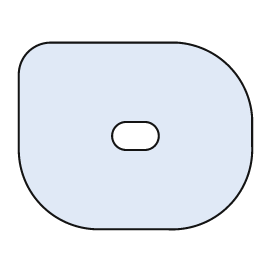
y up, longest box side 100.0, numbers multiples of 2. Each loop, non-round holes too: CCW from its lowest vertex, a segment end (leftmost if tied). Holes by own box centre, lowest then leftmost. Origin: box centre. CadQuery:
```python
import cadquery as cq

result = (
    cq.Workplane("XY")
    .moveTo(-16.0, -40.0)
    .lineTo(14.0, -40.0)
    .threePointArc((40.0, -30.0), (50.0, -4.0))
    .lineTo(50.0, 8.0)
    .threePointArc((40.0, 30.0), (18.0, 40.0))
    .lineTo(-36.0, 40.0)
    .threePointArc((-46.0, 36.0), (-50.0, 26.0))
    .lineTo(-50.0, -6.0)
    .threePointArc((-40.0, -30.0), (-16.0, -40.0))
    .close()
    .moveTo(-4.0, -6.0)
    .lineTo(4.0, -6.0)
    .threePointArc((10.0, 0.0), (4.0, 6.0))
    .lineTo(-4.0, 6.0)
    .threePointArc((-10.0, 0.0), (-4.0, -6.0))
    .close()
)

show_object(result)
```